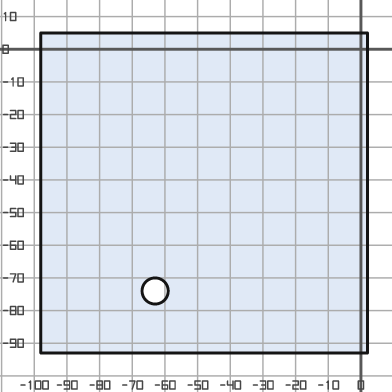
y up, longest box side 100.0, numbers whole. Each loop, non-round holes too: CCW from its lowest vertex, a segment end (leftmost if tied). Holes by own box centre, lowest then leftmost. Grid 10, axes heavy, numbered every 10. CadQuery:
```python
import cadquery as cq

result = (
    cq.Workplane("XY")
    .moveTo(-98.0, -93.0)
    .lineTo(2.0, -93.0)
    .lineTo(2.0, 5.0)
    .lineTo(-98.0, 5.0)
    .close()
    .moveTo(-63.0, -74.0)
    .circle(4.0)
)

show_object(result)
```